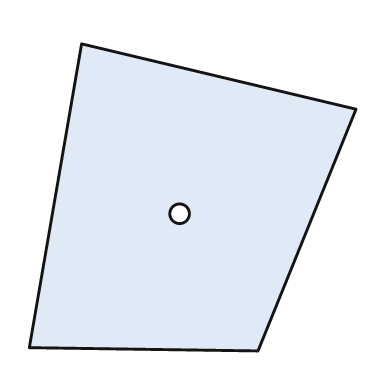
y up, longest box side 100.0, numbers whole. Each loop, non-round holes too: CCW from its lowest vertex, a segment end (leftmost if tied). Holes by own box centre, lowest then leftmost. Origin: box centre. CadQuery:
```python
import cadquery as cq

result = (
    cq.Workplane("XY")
    .moveTo(20.0, -47.0)
    .lineTo(50.0, 27.0)
    .lineTo(-34.0, 47.0)
    .lineTo(-50.0, -46.0)
    .close()
    .moveTo(-4.0, -5.0)
    .circle(3.0)
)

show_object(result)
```